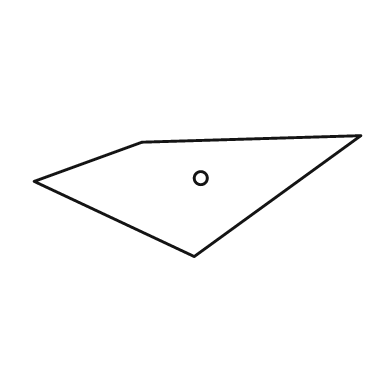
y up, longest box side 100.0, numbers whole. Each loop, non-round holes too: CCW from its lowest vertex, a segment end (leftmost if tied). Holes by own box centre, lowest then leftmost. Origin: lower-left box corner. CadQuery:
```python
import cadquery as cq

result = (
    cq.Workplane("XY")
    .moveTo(49.0, 0.0)
    .lineTo(100.0, 37.0)
    .lineTo(33.0, 35.0)
    .lineTo(0.0, 23.0)
    .close()
    .moveTo(51.0, 24.0)
    .circle(2.0)
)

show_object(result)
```